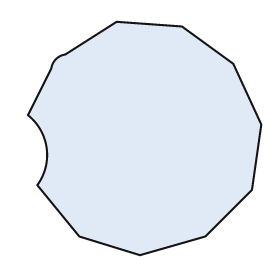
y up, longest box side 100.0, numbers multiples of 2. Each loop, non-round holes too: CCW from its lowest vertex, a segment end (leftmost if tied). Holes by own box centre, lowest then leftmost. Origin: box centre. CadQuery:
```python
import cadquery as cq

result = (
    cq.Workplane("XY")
    .moveTo(-2.0, -50.0)
    .lineTo(26.0, -42.0)
    .lineTo(46.0, -22.0)
    .lineTo(50.0, 6.0)
    .lineTo(38.0, 32.0)
    .lineTo(16.0, 48.0)
    .lineTo(-12.0, 50.0)
    .lineTo(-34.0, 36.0)
    .threePointArc((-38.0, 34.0), (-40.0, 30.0))
    .lineTo(-50.0, 10.0)
    .threePointArc((-42.0, -4.0), (-46.0, -20.0))
    .lineTo(-28.0, -42.0)
    .close()
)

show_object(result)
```